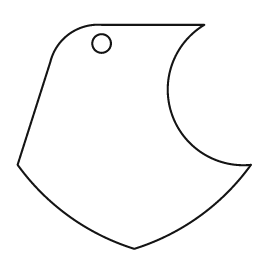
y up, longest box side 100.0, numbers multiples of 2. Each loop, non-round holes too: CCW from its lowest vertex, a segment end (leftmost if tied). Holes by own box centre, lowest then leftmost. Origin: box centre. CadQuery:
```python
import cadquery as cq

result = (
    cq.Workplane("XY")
    .moveTo(0.0, -48.0)
    .threePointArc((28.0, -34.0), (50.0, -12.0))
    .threePointArc((16.0, 10.0), (30.0, 48.0))
    .lineTo(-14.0, 48.0)
    .threePointArc((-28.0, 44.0), (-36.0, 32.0))
    .lineTo(-50.0, -12.0)
    .threePointArc((-28.0, -34.0), (0.0, -48.0))
    .close()
    .moveTo(-14.0, 40.0)
    .circle(4.0)
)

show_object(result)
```